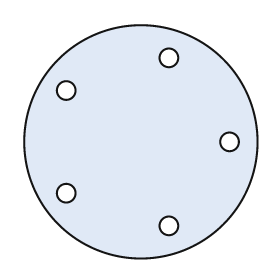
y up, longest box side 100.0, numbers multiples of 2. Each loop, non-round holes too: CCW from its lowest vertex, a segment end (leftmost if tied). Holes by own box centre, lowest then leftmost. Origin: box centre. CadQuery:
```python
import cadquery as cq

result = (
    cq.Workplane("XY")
    .moveTo(0.0, 0.0)
    .circle(50.0)
    .moveTo(12.0, -36.0)
    .circle(4.0)
    .moveTo(-32.0, -22.0)
    .circle(4.0)
    .moveTo(38.0, 0.0)
    .circle(4.0)
    .moveTo(-32.0, 22.0)
    .circle(4.0)
    .moveTo(12.0, 36.0)
    .circle(4.0)
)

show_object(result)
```